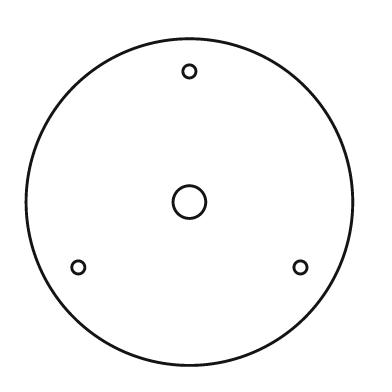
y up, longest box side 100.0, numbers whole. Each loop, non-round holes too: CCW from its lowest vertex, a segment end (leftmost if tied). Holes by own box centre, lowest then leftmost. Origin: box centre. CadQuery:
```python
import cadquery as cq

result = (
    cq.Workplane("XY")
    .moveTo(0.0, 0.0)
    .circle(50.0)
    .moveTo(-34.0, -20.0)
    .circle(2.0)
    .moveTo(34.0, -20.0)
    .circle(2.0)
    .moveTo(0.0, 0.0)
    .circle(5.0)
    .moveTo(0.0, 40.0)
    .circle(2.0)
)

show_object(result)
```